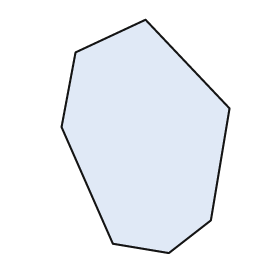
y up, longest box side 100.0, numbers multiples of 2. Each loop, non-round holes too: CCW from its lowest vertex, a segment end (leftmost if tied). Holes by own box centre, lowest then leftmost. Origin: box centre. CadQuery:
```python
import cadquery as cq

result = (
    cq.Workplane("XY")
    .moveTo(10.0, -50.0)
    .lineTo(28.0, -36.0)
    .lineTo(36.0, 12.0)
    .lineTo(0.0, 50.0)
    .lineTo(-30.0, 36.0)
    .lineTo(-36.0, 4.0)
    .lineTo(-14.0, -46.0)
    .close()
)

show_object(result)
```